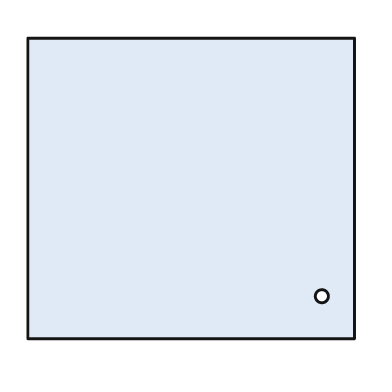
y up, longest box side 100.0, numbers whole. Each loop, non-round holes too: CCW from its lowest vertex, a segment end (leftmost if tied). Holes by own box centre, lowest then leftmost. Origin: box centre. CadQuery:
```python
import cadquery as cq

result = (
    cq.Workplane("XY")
    .moveTo(-50.0, -46.0)
    .lineTo(50.0, -46.0)
    .lineTo(50.0, 46.0)
    .lineTo(-50.0, 46.0)
    .close()
    .moveTo(40.0, -33.0)
    .circle(2.0)
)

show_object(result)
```